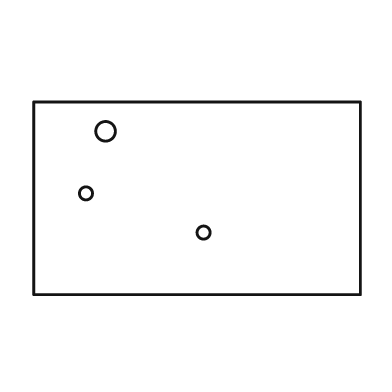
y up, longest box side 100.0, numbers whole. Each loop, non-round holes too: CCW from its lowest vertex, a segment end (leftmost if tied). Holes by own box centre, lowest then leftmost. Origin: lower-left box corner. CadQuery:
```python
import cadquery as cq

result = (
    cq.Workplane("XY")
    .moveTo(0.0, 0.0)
    .lineTo(100.0, 0.0)
    .lineTo(100.0, 59.0)
    .lineTo(0.0, 59.0)
    .close()
    .moveTo(52.0, 19.0)
    .circle(2.0)
    .moveTo(16.0, 31.0)
    .circle(2.0)
    .moveTo(22.0, 50.0)
    .circle(3.0)
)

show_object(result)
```